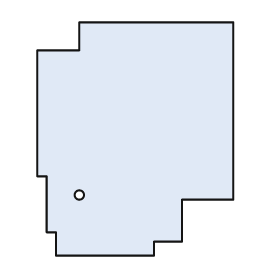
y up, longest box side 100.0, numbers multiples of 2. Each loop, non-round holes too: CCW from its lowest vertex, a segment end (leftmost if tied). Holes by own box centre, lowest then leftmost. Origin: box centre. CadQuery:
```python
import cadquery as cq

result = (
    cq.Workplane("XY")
    .moveTo(-34.0, -50.0)
    .lineTo(8.0, -50.0)
    .lineTo(8.0, -44.0)
    .lineTo(20.0, -44.0)
    .lineTo(20.0, -26.0)
    .lineTo(42.0, -26.0)
    .lineTo(42.0, 50.0)
    .lineTo(-24.0, 50.0)
    .lineTo(-24.0, 38.0)
    .lineTo(-42.0, 38.0)
    .lineTo(-42.0, -16.0)
    .lineTo(-38.0, -16.0)
    .lineTo(-38.0, -40.0)
    .lineTo(-34.0, -40.0)
    .close()
    .moveTo(-24.0, -24.0)
    .circle(2.0)
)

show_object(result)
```